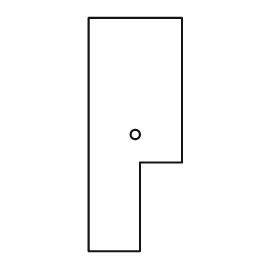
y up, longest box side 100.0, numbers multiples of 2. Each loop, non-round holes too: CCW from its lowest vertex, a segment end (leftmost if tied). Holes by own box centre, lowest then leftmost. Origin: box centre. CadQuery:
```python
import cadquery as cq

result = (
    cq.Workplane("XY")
    .moveTo(-20.0, -50.0)
    .lineTo(2.0, -50.0)
    .lineTo(2.0, -12.0)
    .lineTo(20.0, -12.0)
    .lineTo(20.0, 50.0)
    .lineTo(-20.0, 50.0)
    .close()
    .moveTo(0.0, 0.0)
    .circle(2.0)
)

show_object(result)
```